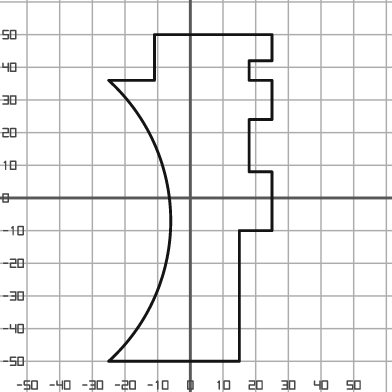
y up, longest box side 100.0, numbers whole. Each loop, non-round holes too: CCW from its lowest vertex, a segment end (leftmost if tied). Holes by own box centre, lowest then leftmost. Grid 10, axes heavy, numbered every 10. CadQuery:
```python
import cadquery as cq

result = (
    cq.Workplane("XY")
    .moveTo(-25.0, -50.0)
    .lineTo(15.0, -50.0)
    .lineTo(15.0, -10.0)
    .lineTo(25.0, -10.0)
    .lineTo(25.0, 8.0)
    .lineTo(18.0, 8.0)
    .lineTo(18.0, 24.0)
    .lineTo(25.0, 24.0)
    .lineTo(25.0, 36.0)
    .lineTo(18.0, 36.0)
    .lineTo(18.0, 42.0)
    .lineTo(25.0, 42.0)
    .lineTo(25.0, 50.0)
    .lineTo(-11.0, 50.0)
    .lineTo(-11.0, 36.0)
    .lineTo(-25.0, 36.0)
    .threePointArc((-6.0, -7.0), (-25.0, -50.0))
    .close()
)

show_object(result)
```